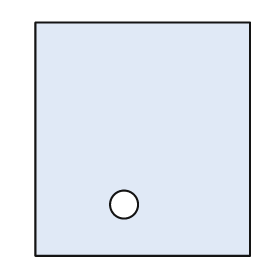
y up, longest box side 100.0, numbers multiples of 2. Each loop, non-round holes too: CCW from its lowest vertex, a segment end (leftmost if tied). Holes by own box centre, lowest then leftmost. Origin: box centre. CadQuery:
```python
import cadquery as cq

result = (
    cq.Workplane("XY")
    .moveTo(-46.0, -50.0)
    .lineTo(46.0, -50.0)
    .lineTo(46.0, 50.0)
    .lineTo(-46.0, 50.0)
    .close()
    .moveTo(-8.0, -28.0)
    .circle(6.0)
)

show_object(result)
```